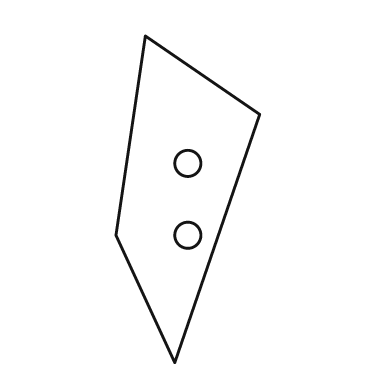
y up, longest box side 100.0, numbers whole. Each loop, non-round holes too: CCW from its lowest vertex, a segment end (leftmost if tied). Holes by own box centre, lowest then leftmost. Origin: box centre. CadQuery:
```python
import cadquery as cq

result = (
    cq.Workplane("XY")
    .moveTo(-4.0, -50.0)
    .lineTo(22.0, 26.0)
    .lineTo(-13.0, 50.0)
    .lineTo(-22.0, -11.0)
    .close()
    .moveTo(0.0, -11.0)
    .circle(4.0)
    .moveTo(0.0, 11.0)
    .circle(4.0)
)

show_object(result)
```